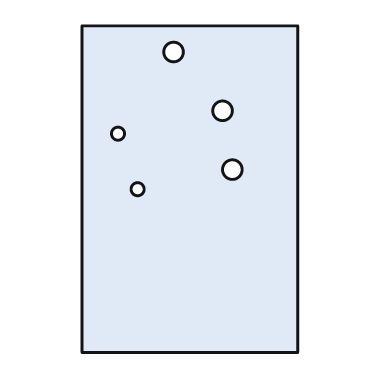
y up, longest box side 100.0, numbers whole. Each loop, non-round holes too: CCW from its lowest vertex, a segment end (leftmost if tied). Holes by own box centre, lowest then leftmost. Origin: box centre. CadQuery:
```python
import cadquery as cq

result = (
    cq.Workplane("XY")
    .moveTo(-33.0, -50.0)
    .lineTo(33.0, -50.0)
    .lineTo(33.0, 50.0)
    .lineTo(-33.0, 50.0)
    .close()
    .moveTo(-16.0, 0.0)
    .circle(2.0)
    .moveTo(13.0, 6.0)
    .circle(3.0)
    .moveTo(-22.0, 17.0)
    .circle(2.0)
    .moveTo(10.0, 24.0)
    .circle(3.0)
    .moveTo(-5.0, 42.0)
    .circle(3.0)
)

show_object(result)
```